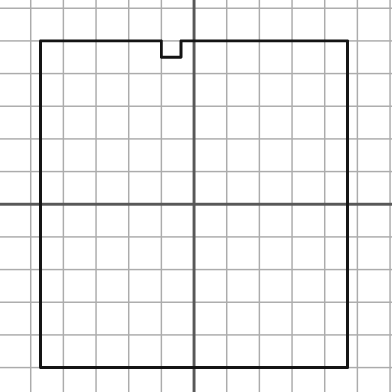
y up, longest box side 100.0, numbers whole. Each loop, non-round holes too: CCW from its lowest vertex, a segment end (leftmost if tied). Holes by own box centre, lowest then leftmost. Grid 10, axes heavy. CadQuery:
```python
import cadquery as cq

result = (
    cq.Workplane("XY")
    .moveTo(-47.0, -50.0)
    .lineTo(47.0, -50.0)
    .lineTo(47.0, 50.0)
    .lineTo(-4.0, 50.0)
    .lineTo(-4.0, 45.0)
    .lineTo(-10.0, 45.0)
    .lineTo(-10.0, 50.0)
    .lineTo(-47.0, 50.0)
    .close()
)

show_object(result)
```